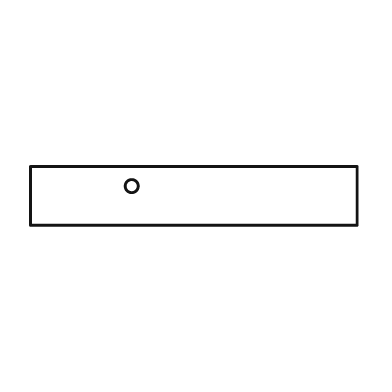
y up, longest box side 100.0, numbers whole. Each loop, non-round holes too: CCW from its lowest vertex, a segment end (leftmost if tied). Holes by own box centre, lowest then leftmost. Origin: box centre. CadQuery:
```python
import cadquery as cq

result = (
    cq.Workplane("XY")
    .moveTo(-50.0, -9.0)
    .lineTo(50.0, -9.0)
    .lineTo(50.0, 9.0)
    .lineTo(-50.0, 9.0)
    .close()
    .moveTo(-19.0, 3.0)
    .circle(2.0)
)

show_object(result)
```